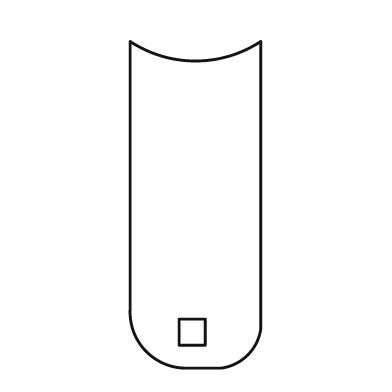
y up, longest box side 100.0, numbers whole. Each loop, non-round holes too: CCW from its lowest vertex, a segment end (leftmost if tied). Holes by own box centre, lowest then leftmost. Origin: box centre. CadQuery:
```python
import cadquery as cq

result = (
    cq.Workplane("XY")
    .moveTo(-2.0, -50.0)
    .lineTo(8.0, -50.0)
    .threePointArc((16.0, -46.0), (20.0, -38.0))
    .lineTo(20.0, 50.0)
    .threePointArc((0.0, 44.0), (-20.0, 50.0))
    .lineTo(-20.0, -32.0)
    .threePointArc((-15.0, -45.0), (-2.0, -50.0))
    .close()
    .moveTo(-5.0, -43.0)
    .lineTo(3.0, -43.0)
    .lineTo(3.0, -35.0)
    .lineTo(-5.0, -35.0)
    .close()
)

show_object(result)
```